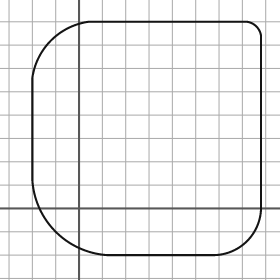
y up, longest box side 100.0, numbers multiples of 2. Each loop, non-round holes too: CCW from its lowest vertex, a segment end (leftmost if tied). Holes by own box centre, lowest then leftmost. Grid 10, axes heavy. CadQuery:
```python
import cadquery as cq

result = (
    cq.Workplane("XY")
    .moveTo(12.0, -20.0)
    .lineTo(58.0, -20.0)
    .threePointArc((72.0, -14.0), (78.0, 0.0))
    .lineTo(78.0, 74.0)
    .threePointArc((76.0, 78.0), (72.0, 80.0))
    .lineTo(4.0, 80.0)
    .threePointArc((-12.0, 72.0), (-20.0, 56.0))
    .lineTo(-20.0, 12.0)
    .threePointArc((-10.0, -10.0), (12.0, -20.0))
    .close()
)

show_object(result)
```